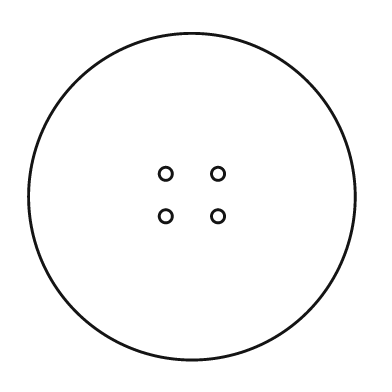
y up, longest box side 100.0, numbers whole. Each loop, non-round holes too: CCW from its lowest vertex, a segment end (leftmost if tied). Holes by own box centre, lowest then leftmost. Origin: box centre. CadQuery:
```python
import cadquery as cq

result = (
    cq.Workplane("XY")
    .moveTo(0.0, 0.0)
    .circle(50.0)
    .moveTo(-8.0, -6.0)
    .circle(2.0)
    .moveTo(8.0, -6.0)
    .circle(2.0)
    .moveTo(-8.0, 7.0)
    .circle(2.0)
    .moveTo(8.0, 7.0)
    .circle(2.0)
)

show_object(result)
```